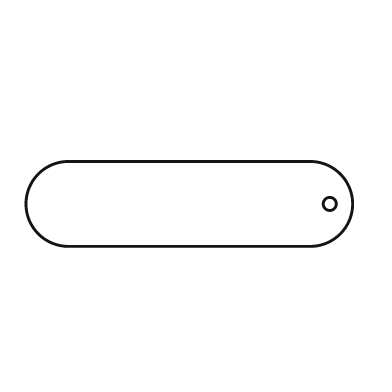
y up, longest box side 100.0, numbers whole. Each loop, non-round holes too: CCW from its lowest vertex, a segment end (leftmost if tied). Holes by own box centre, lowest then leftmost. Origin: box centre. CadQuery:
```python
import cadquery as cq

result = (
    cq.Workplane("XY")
    .moveTo(-37.0, -13.0)
    .lineTo(37.0, -13.0)
    .threePointArc((50.0, 0.0), (37.0, 13.0))
    .lineTo(-37.0, 13.0)
    .threePointArc((-50.0, 0.0), (-37.0, -13.0))
    .close()
    .moveTo(43.0, 0.0)
    .circle(2.0)
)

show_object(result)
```